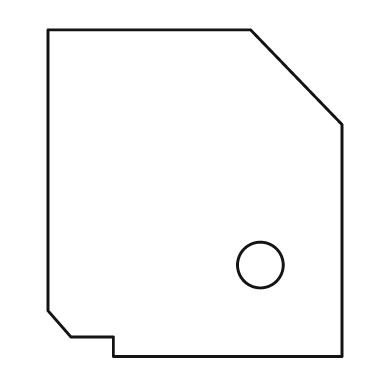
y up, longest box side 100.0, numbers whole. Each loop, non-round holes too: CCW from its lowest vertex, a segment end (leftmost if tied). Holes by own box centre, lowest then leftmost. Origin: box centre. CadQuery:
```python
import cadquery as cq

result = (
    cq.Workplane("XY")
    .moveTo(-25.0, -50.0)
    .lineTo(45.0, -50.0)
    .lineTo(45.0, 21.0)
    .lineTo(17.0, 50.0)
    .lineTo(-45.0, 50.0)
    .lineTo(-45.0, -36.0)
    .lineTo(-38.0, -44.0)
    .lineTo(-25.0, -44.0)
    .close()
    .moveTo(20.0, -22.0)
    .circle(7.0)
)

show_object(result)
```